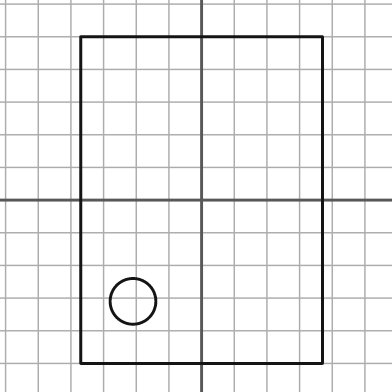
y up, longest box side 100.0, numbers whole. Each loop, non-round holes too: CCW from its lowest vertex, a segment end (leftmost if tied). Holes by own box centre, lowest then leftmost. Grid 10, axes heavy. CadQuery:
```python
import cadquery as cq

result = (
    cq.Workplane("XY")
    .moveTo(-37.0, -50.0)
    .lineTo(37.0, -50.0)
    .lineTo(37.0, 50.0)
    .lineTo(-37.0, 50.0)
    .close()
    .moveTo(-21.0, -31.0)
    .circle(7.0)
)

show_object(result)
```